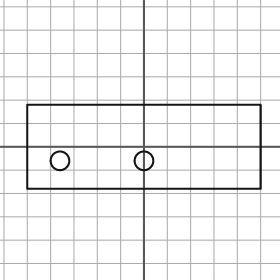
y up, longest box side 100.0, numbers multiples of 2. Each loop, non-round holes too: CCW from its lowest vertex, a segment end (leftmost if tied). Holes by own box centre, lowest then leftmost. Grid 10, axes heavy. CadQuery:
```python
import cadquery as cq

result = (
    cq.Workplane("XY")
    .moveTo(-50.0, -18.0)
    .lineTo(50.0, -18.0)
    .lineTo(50.0, 18.0)
    .lineTo(-50.0, 18.0)
    .close()
    .moveTo(-36.0, -6.0)
    .circle(4.0)
    .moveTo(0.0, -6.0)
    .circle(4.0)
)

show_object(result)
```